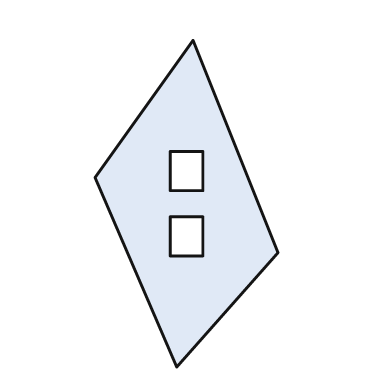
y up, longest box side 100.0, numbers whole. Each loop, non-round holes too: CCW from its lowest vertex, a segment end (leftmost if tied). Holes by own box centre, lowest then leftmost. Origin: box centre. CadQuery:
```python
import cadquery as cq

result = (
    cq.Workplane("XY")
    .moveTo(-3.0, -50.0)
    .lineTo(28.0, -15.0)
    .lineTo(2.0, 50.0)
    .lineTo(-28.0, 8.0)
    .close()
    .moveTo(-5.0, -16.0)
    .lineTo(5.0, -16.0)
    .lineTo(5.0, -4.0)
    .lineTo(-5.0, -4.0)
    .close()
    .moveTo(-5.0, 4.0)
    .lineTo(5.0, 4.0)
    .lineTo(5.0, 16.0)
    .lineTo(-5.0, 16.0)
    .close()
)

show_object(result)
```